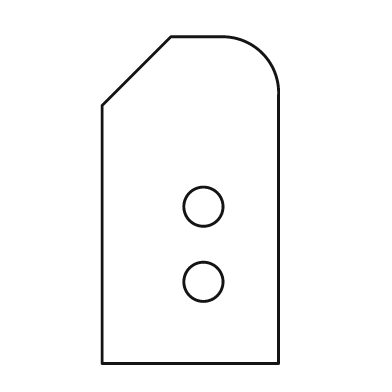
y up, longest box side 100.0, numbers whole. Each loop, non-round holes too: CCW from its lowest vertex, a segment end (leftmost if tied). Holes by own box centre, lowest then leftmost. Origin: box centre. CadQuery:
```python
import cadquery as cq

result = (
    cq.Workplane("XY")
    .moveTo(-27.0, -50.0)
    .lineTo(27.0, -50.0)
    .lineTo(27.0, 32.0)
    .threePointArc((22.0, 45.0), (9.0, 50.0))
    .lineTo(-6.0, 50.0)
    .lineTo(-27.0, 29.0)
    .close()
    .moveTo(4.0, -25.0)
    .circle(6.0)
    .moveTo(4.0, -2.0)
    .circle(6.0)
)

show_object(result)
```